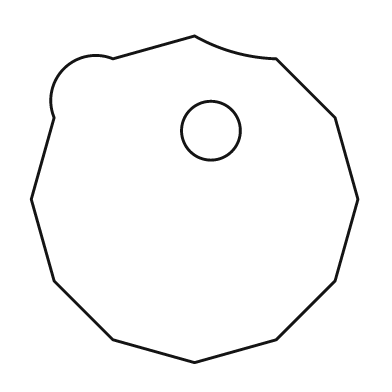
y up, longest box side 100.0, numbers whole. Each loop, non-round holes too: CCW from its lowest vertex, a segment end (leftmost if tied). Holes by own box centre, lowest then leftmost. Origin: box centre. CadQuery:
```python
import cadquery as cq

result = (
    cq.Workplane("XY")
    .moveTo(0.0, -50.0)
    .lineTo(25.0, -43.0)
    .lineTo(43.0, -25.0)
    .lineTo(50.0, 0.0)
    .lineTo(43.0, 25.0)
    .lineTo(25.0, 43.0)
    .threePointArc((12.0, 45.0), (0.0, 50.0))
    .lineTo(-25.0, 43.0)
    .threePointArc((-40.0, 40.0), (-43.0, 25.0))
    .lineTo(-50.0, 0.0)
    .lineTo(-43.0, -25.0)
    .lineTo(-25.0, -43.0)
    .close()
    .moveTo(5.0, 21.0)
    .circle(9.0)
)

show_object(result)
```